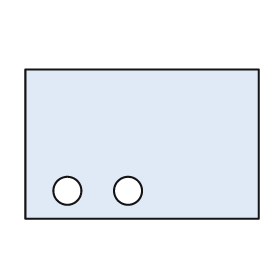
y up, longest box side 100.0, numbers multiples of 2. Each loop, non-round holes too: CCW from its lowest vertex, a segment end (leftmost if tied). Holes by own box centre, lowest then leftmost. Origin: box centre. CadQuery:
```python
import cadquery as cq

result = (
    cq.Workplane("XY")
    .moveTo(-50.0, -32.0)
    .lineTo(50.0, -32.0)
    .lineTo(50.0, 32.0)
    .lineTo(-50.0, 32.0)
    .close()
    .moveTo(-32.0, -20.0)
    .circle(6.0)
    .moveTo(-6.0, -20.0)
    .circle(6.0)
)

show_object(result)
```